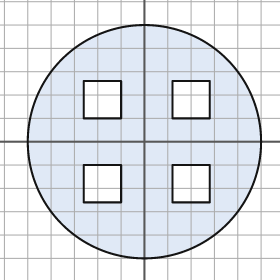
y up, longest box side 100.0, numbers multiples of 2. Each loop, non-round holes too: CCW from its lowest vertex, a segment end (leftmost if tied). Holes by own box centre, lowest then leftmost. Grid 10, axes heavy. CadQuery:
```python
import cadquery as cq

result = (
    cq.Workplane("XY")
    .moveTo(0.0, 0.0)
    .circle(50.0)
    .moveTo(-26.0, -26.0)
    .lineTo(-10.0, -26.0)
    .lineTo(-10.0, -10.0)
    .lineTo(-26.0, -10.0)
    .close()
    .moveTo(12.0, -26.0)
    .lineTo(28.0, -26.0)
    .lineTo(28.0, -10.0)
    .lineTo(12.0, -10.0)
    .close()
    .moveTo(-26.0, 10.0)
    .lineTo(-10.0, 10.0)
    .lineTo(-10.0, 26.0)
    .lineTo(-26.0, 26.0)
    .close()
    .moveTo(12.0, 10.0)
    .lineTo(28.0, 10.0)
    .lineTo(28.0, 26.0)
    .lineTo(12.0, 26.0)
    .close()
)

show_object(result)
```